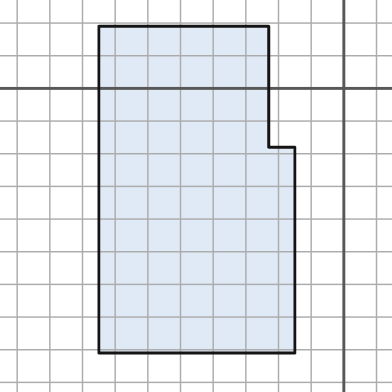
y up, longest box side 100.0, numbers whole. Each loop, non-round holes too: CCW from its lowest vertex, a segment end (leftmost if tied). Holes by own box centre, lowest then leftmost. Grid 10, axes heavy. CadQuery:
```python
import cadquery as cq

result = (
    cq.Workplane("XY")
    .moveTo(-75.0, -81.0)
    .lineTo(-15.0, -81.0)
    .lineTo(-15.0, -18.0)
    .lineTo(-23.0, -18.0)
    .lineTo(-23.0, 19.0)
    .lineTo(-75.0, 19.0)
    .close()
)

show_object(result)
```